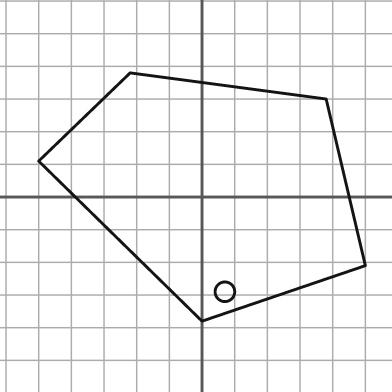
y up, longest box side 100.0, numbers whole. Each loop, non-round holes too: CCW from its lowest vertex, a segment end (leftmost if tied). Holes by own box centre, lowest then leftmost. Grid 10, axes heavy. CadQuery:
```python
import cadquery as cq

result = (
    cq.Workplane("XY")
    .moveTo(0.0, -38.0)
    .lineTo(50.0, -21.0)
    .lineTo(38.0, 30.0)
    .lineTo(-22.0, 38.0)
    .lineTo(-50.0, 11.0)
    .close()
    .moveTo(7.0, -29.0)
    .circle(3.0)
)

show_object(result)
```